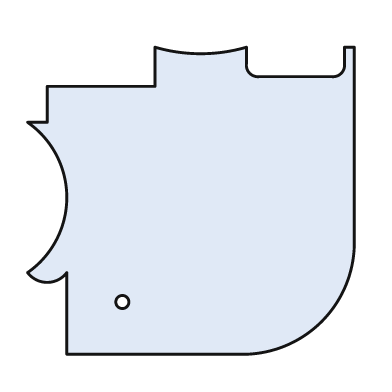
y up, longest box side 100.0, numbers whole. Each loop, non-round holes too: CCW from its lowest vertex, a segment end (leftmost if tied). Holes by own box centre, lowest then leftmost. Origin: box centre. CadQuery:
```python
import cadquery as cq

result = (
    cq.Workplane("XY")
    .moveTo(-38.0, -47.0)
    .lineTo(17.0, -47.0)
    .threePointArc((40.0, -37.0), (50.0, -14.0))
    .lineTo(50.0, 47.0)
    .lineTo(47.0, 47.0)
    .lineTo(47.0, 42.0)
    .threePointArc((46.0, 39.0), (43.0, 38.0))
    .lineTo(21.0, 38.0)
    .threePointArc((18.0, 39.0), (17.0, 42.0))
    .lineTo(17.0, 47.0)
    .threePointArc((3.0, 45.0), (-11.0, 47.0))
    .lineTo(-11.0, 35.0)
    .lineTo(-44.0, 35.0)
    .lineTo(-44.0, 24.0)
    .lineTo(-50.0, 24.0)
    .threePointArc((-38.0, 1.0), (-50.0, -22.0))
    .threePointArc((-44.0, -25.0), (-38.0, -22.0))
    .close()
    .moveTo(-21.0, -31.0)
    .circle(2.0)
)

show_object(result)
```